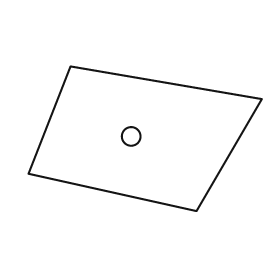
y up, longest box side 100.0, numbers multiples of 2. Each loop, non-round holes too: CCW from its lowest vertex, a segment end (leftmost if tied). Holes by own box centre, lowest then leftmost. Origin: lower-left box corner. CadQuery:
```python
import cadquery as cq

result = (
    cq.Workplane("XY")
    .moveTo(72.0, 0.0)
    .lineTo(100.0, 48.0)
    .lineTo(18.0, 62.0)
    .lineTo(0.0, 16.0)
    .close()
    .moveTo(44.0, 32.0)
    .circle(4.0)
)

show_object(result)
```